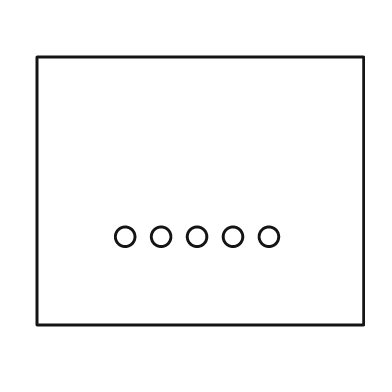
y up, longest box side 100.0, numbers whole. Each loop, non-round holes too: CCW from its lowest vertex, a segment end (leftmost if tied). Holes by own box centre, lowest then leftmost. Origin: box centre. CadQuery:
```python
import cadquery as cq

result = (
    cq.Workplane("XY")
    .moveTo(-50.0, -41.0)
    .lineTo(50.0, -41.0)
    .lineTo(50.0, 41.0)
    .lineTo(-50.0, 41.0)
    .close()
    .moveTo(-23.0, -14.0)
    .circle(3.0)
    .moveTo(-12.0, -14.0)
    .circle(3.0)
    .moveTo(-1.0, -14.0)
    .circle(3.0)
    .moveTo(10.0, -14.0)
    .circle(3.0)
    .moveTo(21.0, -14.0)
    .circle(3.0)
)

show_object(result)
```